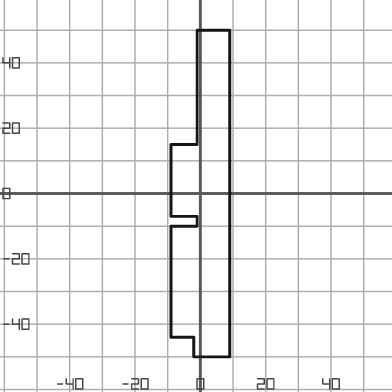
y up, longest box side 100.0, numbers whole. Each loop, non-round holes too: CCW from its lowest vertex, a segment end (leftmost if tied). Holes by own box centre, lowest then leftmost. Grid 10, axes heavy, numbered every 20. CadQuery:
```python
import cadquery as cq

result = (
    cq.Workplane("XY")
    .moveTo(-2.0, -50.0)
    .lineTo(9.0, -50.0)
    .lineTo(9.0, 50.0)
    .lineTo(-1.0, 50.0)
    .lineTo(-1.0, 15.0)
    .lineTo(-9.0, 15.0)
    .lineTo(-9.0, -7.0)
    .lineTo(-1.0, -7.0)
    .lineTo(-1.0, -10.0)
    .lineTo(-9.0, -10.0)
    .lineTo(-9.0, -44.0)
    .lineTo(-2.0, -44.0)
    .close()
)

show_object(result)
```